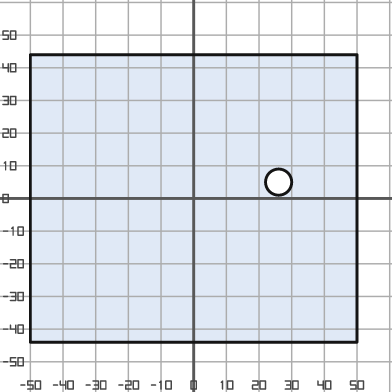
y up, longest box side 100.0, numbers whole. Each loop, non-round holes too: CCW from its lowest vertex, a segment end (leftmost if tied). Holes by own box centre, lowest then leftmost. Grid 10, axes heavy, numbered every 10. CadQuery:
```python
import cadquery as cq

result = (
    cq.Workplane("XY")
    .moveTo(-50.0, -44.0)
    .lineTo(50.0, -44.0)
    .lineTo(50.0, 44.0)
    .lineTo(-50.0, 44.0)
    .close()
    .moveTo(26.0, 5.0)
    .circle(4.0)
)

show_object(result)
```